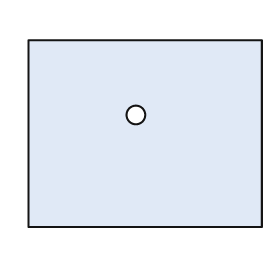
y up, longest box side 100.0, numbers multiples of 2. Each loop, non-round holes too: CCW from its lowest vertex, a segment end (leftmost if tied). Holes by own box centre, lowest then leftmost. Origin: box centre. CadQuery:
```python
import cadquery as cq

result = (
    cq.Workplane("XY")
    .moveTo(-50.0, -40.0)
    .lineTo(50.0, -40.0)
    .lineTo(50.0, 40.0)
    .lineTo(-50.0, 40.0)
    .close()
    .moveTo(-4.0, 8.0)
    .circle(4.0)
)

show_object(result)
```